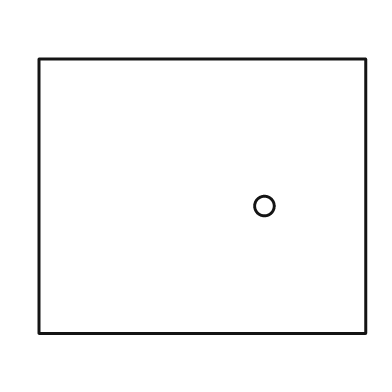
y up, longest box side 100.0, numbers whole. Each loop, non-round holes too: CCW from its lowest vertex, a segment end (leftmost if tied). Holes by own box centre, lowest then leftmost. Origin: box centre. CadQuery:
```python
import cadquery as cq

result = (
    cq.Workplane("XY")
    .moveTo(-50.0, -42.0)
    .lineTo(50.0, -42.0)
    .lineTo(50.0, 42.0)
    .lineTo(-50.0, 42.0)
    .close()
    .moveTo(19.0, -3.0)
    .circle(3.0)
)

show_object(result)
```